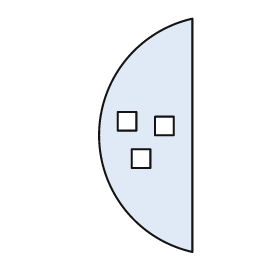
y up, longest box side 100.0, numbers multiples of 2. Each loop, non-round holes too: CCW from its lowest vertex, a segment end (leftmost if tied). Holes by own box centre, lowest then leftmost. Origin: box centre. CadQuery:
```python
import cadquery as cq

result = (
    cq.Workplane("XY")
    .moveTo(20.0, -50.0)
    .lineTo(20.0, 50.0)
    .threePointArc((-20.0, 0.0), (20.0, -50.0))
    .close()
    .moveTo(-6.0, -14.0)
    .lineTo(2.0, -14.0)
    .lineTo(2.0, -6.0)
    .lineTo(-6.0, -6.0)
    .close()
    .moveTo(4.0, 0.0)
    .lineTo(12.0, 0.0)
    .lineTo(12.0, 8.0)
    .lineTo(4.0, 8.0)
    .close()
    .moveTo(-12.0, 2.0)
    .lineTo(-4.0, 2.0)
    .lineTo(-4.0, 10.0)
    .lineTo(-12.0, 10.0)
    .close()
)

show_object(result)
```